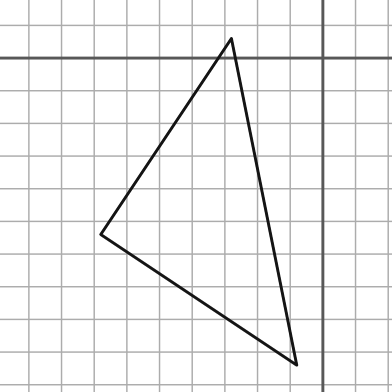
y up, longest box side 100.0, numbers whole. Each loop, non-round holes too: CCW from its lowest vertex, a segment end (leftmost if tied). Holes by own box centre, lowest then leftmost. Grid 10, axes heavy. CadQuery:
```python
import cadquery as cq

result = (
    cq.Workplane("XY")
    .moveTo(-8.0, -94.0)
    .lineTo(-28.0, 6.0)
    .lineTo(-68.0, -54.0)
    .close()
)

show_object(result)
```